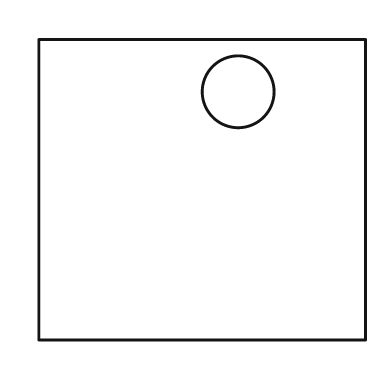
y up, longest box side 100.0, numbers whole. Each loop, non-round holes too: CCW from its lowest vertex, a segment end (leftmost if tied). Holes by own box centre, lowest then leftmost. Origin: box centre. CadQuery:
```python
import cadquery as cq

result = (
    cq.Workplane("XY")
    .moveTo(-50.0, -46.0)
    .lineTo(50.0, -46.0)
    .lineTo(50.0, 46.0)
    .lineTo(-50.0, 46.0)
    .close()
    .moveTo(11.0, 30.0)
    .circle(11.0)
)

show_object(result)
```